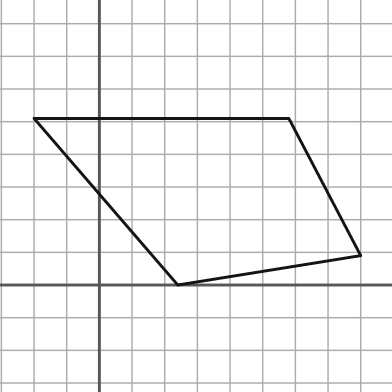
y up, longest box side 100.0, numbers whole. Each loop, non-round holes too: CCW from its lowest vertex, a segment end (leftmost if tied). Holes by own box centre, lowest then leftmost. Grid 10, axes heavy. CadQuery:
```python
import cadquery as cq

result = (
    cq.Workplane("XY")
    .moveTo(24.0, 0.0)
    .lineTo(80.0, 9.0)
    .lineTo(58.0, 51.0)
    .lineTo(-20.0, 51.0)
    .close()
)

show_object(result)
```